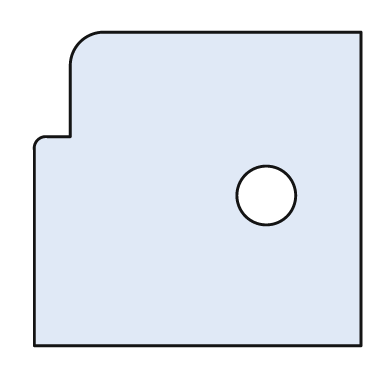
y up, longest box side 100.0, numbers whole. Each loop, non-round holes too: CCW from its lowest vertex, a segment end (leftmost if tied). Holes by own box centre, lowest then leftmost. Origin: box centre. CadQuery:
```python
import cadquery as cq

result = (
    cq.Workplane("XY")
    .moveTo(-50.0, -48.0)
    .lineTo(50.0, -48.0)
    .lineTo(50.0, 48.0)
    .lineTo(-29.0, 48.0)
    .threePointArc((-36.0, 45.0), (-39.0, 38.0))
    .lineTo(-39.0, 16.0)
    .lineTo(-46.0, 16.0)
    .threePointArc((-49.0, 15.0), (-50.0, 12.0))
    .close()
    .moveTo(21.0, -2.0)
    .circle(9.0)
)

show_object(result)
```